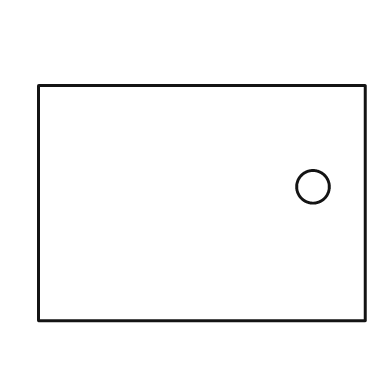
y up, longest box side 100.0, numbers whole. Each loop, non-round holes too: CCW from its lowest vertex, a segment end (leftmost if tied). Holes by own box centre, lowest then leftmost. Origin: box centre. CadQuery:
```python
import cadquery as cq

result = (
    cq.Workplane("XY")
    .moveTo(-50.0, -36.0)
    .lineTo(50.0, -36.0)
    .lineTo(50.0, 36.0)
    .lineTo(-50.0, 36.0)
    .close()
    .moveTo(34.0, 5.0)
    .circle(5.0)
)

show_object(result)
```